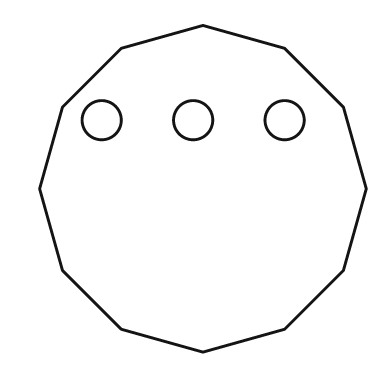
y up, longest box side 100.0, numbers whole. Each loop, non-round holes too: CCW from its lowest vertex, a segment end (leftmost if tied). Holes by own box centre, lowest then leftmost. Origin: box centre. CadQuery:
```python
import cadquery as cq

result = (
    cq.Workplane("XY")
    .moveTo(0.0, -50.0)
    .lineTo(25.0, -43.0)
    .lineTo(43.0, -25.0)
    .lineTo(50.0, 0.0)
    .lineTo(43.0, 25.0)
    .lineTo(25.0, 43.0)
    .lineTo(0.0, 50.0)
    .lineTo(-25.0, 43.0)
    .lineTo(-43.0, 25.0)
    .lineTo(-50.0, 0.0)
    .lineTo(-43.0, -25.0)
    .lineTo(-25.0, -43.0)
    .close()
    .moveTo(-31.0, 21.0)
    .circle(6.0)
    .moveTo(-3.0, 21.0)
    .circle(6.0)
    .moveTo(25.0, 21.0)
    .circle(6.0)
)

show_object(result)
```